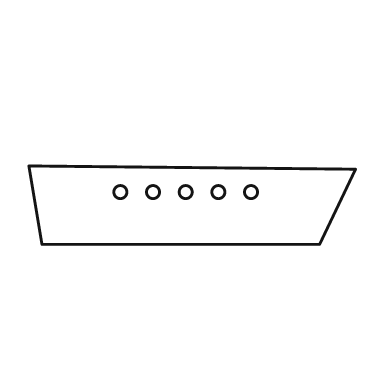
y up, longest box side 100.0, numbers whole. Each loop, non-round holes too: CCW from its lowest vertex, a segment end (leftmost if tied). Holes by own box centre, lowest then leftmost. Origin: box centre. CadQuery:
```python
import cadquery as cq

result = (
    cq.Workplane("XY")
    .moveTo(-46.0, -12.0)
    .lineTo(39.0, -12.0)
    .lineTo(50.0, 11.0)
    .lineTo(-50.0, 12.0)
    .close()
    .moveTo(-22.0, 4.0)
    .circle(2.0)
    .moveTo(-12.0, 4.0)
    .circle(2.0)
    .moveTo(-2.0, 4.0)
    .circle(2.0)
    .moveTo(8.0, 4.0)
    .circle(2.0)
    .moveTo(18.0, 4.0)
    .circle(2.0)
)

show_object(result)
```